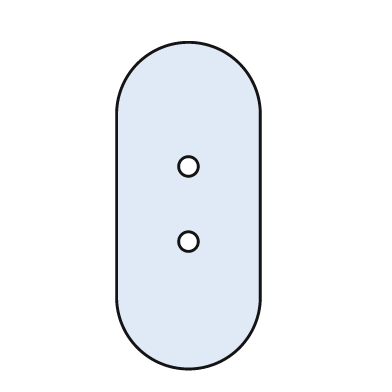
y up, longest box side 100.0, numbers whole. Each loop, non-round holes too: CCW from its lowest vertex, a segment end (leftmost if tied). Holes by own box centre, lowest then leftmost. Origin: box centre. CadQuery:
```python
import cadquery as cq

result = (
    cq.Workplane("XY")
    .moveTo(-22.0, -28.0)
    .threePointArc((0.0, -50.0), (22.0, -28.0))
    .lineTo(22.0, 28.0)
    .threePointArc((0.0, 50.0), (-22.0, 28.0))
    .close()
    .moveTo(0.0, -11.0)
    .circle(3.0)
    .moveTo(0.0, 12.0)
    .circle(3.0)
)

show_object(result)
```